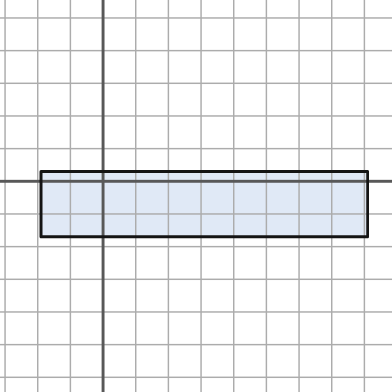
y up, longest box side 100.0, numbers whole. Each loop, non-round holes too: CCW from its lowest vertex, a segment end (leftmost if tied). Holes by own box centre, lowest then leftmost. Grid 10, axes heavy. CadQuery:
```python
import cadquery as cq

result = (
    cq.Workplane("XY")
    .moveTo(-19.0, -17.0)
    .lineTo(81.0, -17.0)
    .lineTo(81.0, 3.0)
    .lineTo(-19.0, 3.0)
    .close()
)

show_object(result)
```